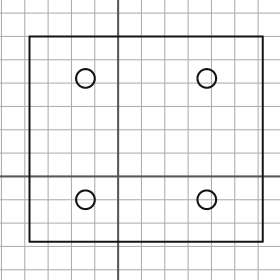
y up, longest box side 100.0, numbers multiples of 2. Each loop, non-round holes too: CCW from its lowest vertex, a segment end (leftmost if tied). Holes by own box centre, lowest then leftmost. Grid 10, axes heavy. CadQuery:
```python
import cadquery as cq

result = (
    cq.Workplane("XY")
    .moveTo(-38.0, -28.0)
    .lineTo(62.0, -28.0)
    .lineTo(62.0, 60.0)
    .lineTo(-38.0, 60.0)
    .close()
    .moveTo(-14.0, -10.0)
    .circle(4.0)
    .moveTo(38.0, -10.0)
    .circle(4.0)
    .moveTo(-14.0, 42.0)
    .circle(4.0)
    .moveTo(38.0, 42.0)
    .circle(4.0)
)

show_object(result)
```